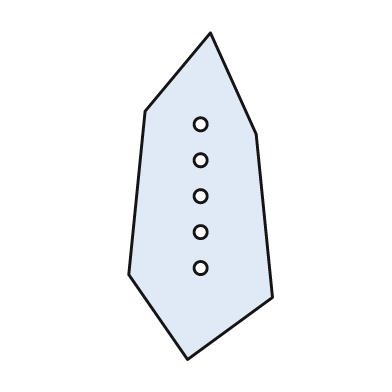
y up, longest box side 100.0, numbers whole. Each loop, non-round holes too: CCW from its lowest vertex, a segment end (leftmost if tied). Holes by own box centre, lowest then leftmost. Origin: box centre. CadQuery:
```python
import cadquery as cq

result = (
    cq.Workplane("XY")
    .moveTo(-4.0, -50.0)
    .lineTo(22.0, -31.0)
    .lineTo(17.0, 19.0)
    .lineTo(3.0, 50.0)
    .lineTo(-17.0, 26.0)
    .lineTo(-22.0, -24.0)
    .close()
    .moveTo(0.0, -22.0)
    .circle(2.0)
    .moveTo(0.0, -11.0)
    .circle(2.0)
    .moveTo(0.0, 0.0)
    .circle(2.0)
    .moveTo(0.0, 11.0)
    .circle(2.0)
    .moveTo(0.0, 22.0)
    .circle(2.0)
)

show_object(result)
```